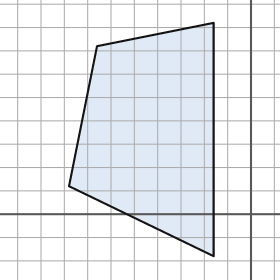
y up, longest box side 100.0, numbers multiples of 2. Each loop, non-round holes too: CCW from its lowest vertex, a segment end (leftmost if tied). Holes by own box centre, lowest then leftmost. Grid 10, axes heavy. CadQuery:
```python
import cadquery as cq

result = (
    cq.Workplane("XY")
    .moveTo(-16.0, -18.0)
    .lineTo(-16.0, 82.0)
    .lineTo(-66.0, 72.0)
    .lineTo(-78.0, 12.0)
    .close()
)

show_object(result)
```